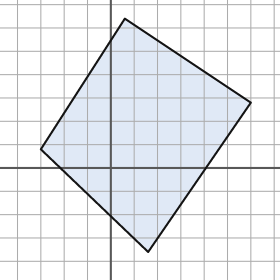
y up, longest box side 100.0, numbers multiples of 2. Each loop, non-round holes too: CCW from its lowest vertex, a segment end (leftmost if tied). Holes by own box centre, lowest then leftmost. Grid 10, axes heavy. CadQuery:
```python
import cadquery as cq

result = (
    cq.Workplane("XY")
    .moveTo(16.0, -36.0)
    .lineTo(60.0, 28.0)
    .lineTo(6.0, 64.0)
    .lineTo(-30.0, 8.0)
    .close()
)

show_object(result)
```